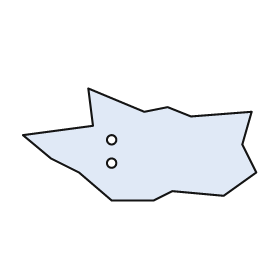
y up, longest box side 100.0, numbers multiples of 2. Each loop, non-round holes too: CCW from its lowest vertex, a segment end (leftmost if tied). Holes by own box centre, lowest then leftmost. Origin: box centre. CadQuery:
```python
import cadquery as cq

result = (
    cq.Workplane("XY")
    .moveTo(-12.0, -24.0)
    .lineTo(6.0, -24.0)
    .lineTo(14.0, -20.0)
    .lineTo(36.0, -22.0)
    .lineTo(50.0, -12.0)
    .lineTo(44.0, 0.0)
    .lineTo(48.0, 14.0)
    .lineTo(22.0, 12.0)
    .lineTo(12.0, 16.0)
    .lineTo(2.0, 14.0)
    .lineTo(-22.0, 24.0)
    .lineTo(-20.0, 8.0)
    .lineTo(-50.0, 4.0)
    .lineTo(-38.0, -6.0)
    .lineTo(-26.0, -12.0)
    .close()
    .moveTo(-12.0, -8.0)
    .circle(2.0)
    .moveTo(-12.0, 2.0)
    .circle(2.0)
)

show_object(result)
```